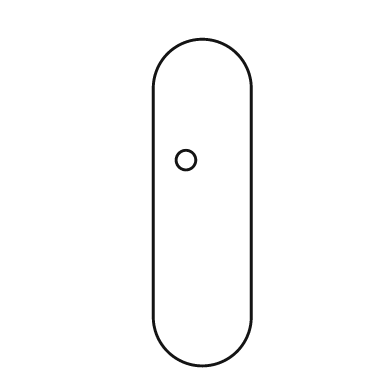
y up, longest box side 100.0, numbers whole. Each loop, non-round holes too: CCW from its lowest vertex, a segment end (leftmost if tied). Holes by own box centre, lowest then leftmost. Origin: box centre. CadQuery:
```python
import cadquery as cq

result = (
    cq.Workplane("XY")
    .moveTo(-15.0, -35.0)
    .threePointArc((0.0, -50.0), (15.0, -35.0))
    .lineTo(15.0, 35.0)
    .threePointArc((0.0, 50.0), (-15.0, 35.0))
    .close()
    .moveTo(-5.0, 13.0)
    .circle(3.0)
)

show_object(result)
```